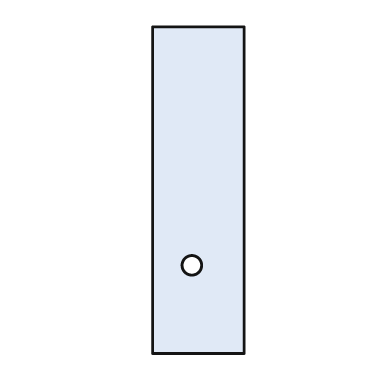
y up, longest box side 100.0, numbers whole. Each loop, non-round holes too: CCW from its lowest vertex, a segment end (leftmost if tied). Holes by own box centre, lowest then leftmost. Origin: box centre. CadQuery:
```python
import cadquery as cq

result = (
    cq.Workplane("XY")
    .moveTo(-14.0, -50.0)
    .lineTo(14.0, -50.0)
    .lineTo(14.0, 50.0)
    .lineTo(-14.0, 50.0)
    .close()
    .moveTo(-2.0, -23.0)
    .circle(3.0)
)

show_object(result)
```